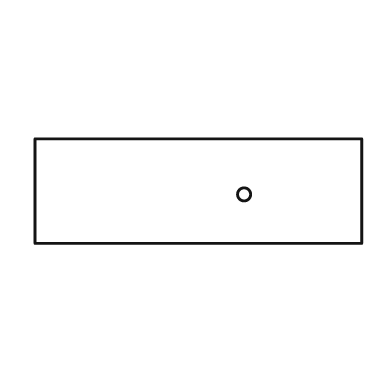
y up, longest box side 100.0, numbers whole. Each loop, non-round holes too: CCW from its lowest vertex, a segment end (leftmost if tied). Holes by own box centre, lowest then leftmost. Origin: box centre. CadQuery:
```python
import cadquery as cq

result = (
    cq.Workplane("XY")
    .moveTo(-50.0, -16.0)
    .lineTo(50.0, -16.0)
    .lineTo(50.0, 16.0)
    .lineTo(-50.0, 16.0)
    .close()
    .moveTo(14.0, -1.0)
    .circle(2.0)
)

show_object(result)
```